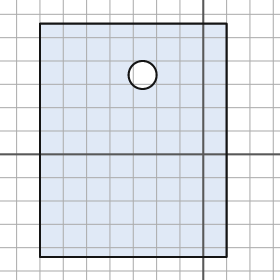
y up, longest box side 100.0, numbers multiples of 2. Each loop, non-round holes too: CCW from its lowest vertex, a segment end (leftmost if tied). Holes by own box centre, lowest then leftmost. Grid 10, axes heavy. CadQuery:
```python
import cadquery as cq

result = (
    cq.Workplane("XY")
    .moveTo(-70.0, -44.0)
    .lineTo(10.0, -44.0)
    .lineTo(10.0, 56.0)
    .lineTo(-70.0, 56.0)
    .close()
    .moveTo(-26.0, 34.0)
    .circle(6.0)
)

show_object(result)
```